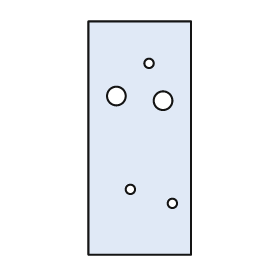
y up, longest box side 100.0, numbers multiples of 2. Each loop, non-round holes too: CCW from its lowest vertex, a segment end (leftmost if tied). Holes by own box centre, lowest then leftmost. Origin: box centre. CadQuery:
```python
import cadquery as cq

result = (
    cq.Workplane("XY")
    .moveTo(-22.0, -50.0)
    .lineTo(22.0, -50.0)
    .lineTo(22.0, 50.0)
    .lineTo(-22.0, 50.0)
    .close()
    .moveTo(14.0, -28.0)
    .circle(2.0)
    .moveTo(-4.0, -22.0)
    .circle(2.0)
    .moveTo(10.0, 16.0)
    .circle(4.0)
    .moveTo(-10.0, 18.0)
    .circle(4.0)
    .moveTo(4.0, 32.0)
    .circle(2.0)
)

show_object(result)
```